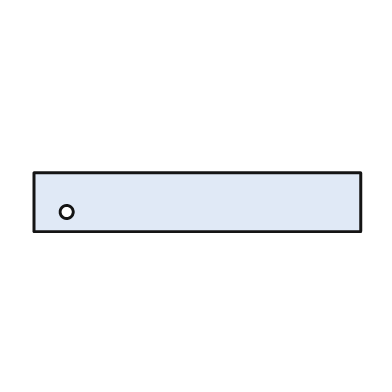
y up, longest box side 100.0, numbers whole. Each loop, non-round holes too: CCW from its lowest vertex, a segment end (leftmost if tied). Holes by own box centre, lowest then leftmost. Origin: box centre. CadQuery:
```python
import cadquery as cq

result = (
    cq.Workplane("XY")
    .moveTo(-50.0, -9.0)
    .lineTo(50.0, -9.0)
    .lineTo(50.0, 9.0)
    .lineTo(-50.0, 9.0)
    .close()
    .moveTo(-40.0, -3.0)
    .circle(2.0)
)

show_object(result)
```